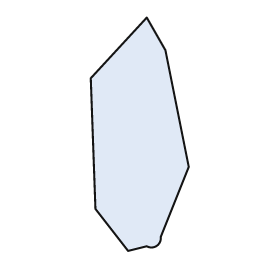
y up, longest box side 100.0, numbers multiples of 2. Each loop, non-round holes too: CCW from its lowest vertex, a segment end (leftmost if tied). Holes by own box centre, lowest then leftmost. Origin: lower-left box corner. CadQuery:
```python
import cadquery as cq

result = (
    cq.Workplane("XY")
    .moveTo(16.0, 0.0)
    .lineTo(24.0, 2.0)
    .threePointArc((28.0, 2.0), (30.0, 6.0))
    .lineTo(42.0, 36.0)
    .lineTo(32.0, 86.0)
    .lineTo(24.0, 100.0)
    .lineTo(0.0, 74.0)
    .lineTo(2.0, 18.0)
    .close()
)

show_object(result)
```